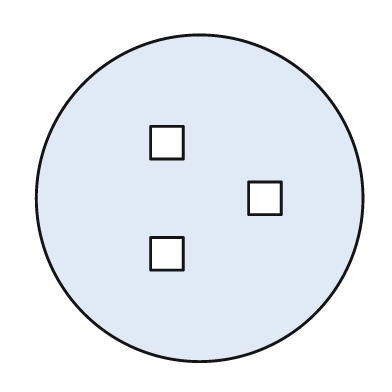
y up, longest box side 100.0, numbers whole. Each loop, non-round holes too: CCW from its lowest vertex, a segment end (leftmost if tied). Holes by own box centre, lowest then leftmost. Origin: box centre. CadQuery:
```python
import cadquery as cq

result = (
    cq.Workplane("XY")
    .moveTo(0.0, 0.0)
    .circle(50.0)
    .moveTo(-15.0, -22.0)
    .lineTo(-5.0, -22.0)
    .lineTo(-5.0, -12.0)
    .lineTo(-15.0, -12.0)
    .close()
    .moveTo(15.0, -5.0)
    .lineTo(25.0, -5.0)
    .lineTo(25.0, 5.0)
    .lineTo(15.0, 5.0)
    .close()
    .moveTo(-15.0, 12.0)
    .lineTo(-5.0, 12.0)
    .lineTo(-5.0, 22.0)
    .lineTo(-15.0, 22.0)
    .close()
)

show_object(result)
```